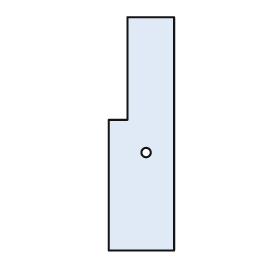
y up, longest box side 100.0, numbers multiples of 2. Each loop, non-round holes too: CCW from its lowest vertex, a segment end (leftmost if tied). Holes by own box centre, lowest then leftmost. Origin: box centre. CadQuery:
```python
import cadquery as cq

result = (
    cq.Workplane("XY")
    .moveTo(-14.0, -50.0)
    .lineTo(14.0, -50.0)
    .lineTo(14.0, 50.0)
    .lineTo(-6.0, 50.0)
    .lineTo(-6.0, 6.0)
    .lineTo(-14.0, 6.0)
    .close()
    .moveTo(2.0, -8.0)
    .circle(2.0)
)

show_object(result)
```